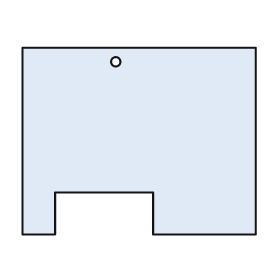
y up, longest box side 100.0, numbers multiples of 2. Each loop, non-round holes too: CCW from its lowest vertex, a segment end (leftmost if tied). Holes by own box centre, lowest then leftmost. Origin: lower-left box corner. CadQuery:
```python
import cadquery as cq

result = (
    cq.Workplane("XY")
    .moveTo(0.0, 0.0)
    .lineTo(14.0, 0.0)
    .lineTo(14.0, 18.0)
    .lineTo(56.0, 18.0)
    .lineTo(56.0, 0.0)
    .lineTo(100.0, 0.0)
    .lineTo(100.0, 80.0)
    .lineTo(0.0, 80.0)
    .close()
    .moveTo(40.0, 74.0)
    .circle(2.0)
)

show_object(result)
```